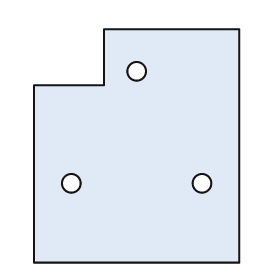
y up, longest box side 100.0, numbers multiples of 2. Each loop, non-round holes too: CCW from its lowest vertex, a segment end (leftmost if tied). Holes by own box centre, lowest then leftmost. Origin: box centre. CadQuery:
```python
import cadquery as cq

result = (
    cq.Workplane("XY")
    .moveTo(-44.0, -50.0)
    .lineTo(44.0, -50.0)
    .lineTo(44.0, 50.0)
    .lineTo(-14.0, 50.0)
    .lineTo(-14.0, 26.0)
    .lineTo(-44.0, 26.0)
    .close()
    .moveTo(-28.0, -16.0)
    .circle(4.0)
    .moveTo(28.0, -16.0)
    .circle(4.0)
    .moveTo(0.0, 32.0)
    .circle(4.0)
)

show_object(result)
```